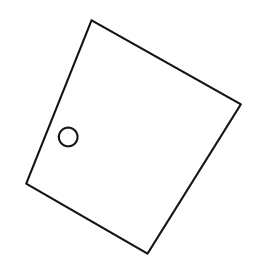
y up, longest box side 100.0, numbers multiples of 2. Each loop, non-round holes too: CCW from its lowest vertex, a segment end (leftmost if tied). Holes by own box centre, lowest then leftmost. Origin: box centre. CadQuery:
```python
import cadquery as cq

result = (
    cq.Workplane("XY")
    .moveTo(6.0, -50.0)
    .lineTo(46.0, 14.0)
    .lineTo(-18.0, 50.0)
    .lineTo(-46.0, -20.0)
    .close()
    .moveTo(-28.0, 0.0)
    .circle(4.0)
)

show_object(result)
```